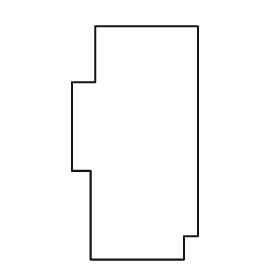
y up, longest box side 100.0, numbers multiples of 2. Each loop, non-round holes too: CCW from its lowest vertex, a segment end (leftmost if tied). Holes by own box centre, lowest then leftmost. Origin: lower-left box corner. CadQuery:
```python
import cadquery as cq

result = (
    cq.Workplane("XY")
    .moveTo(8.0, 0.0)
    .lineTo(48.0, 0.0)
    .lineTo(48.0, 10.0)
    .lineTo(54.0, 10.0)
    .lineTo(54.0, 100.0)
    .lineTo(10.0, 100.0)
    .lineTo(10.0, 76.0)
    .lineTo(0.0, 76.0)
    .lineTo(0.0, 38.0)
    .lineTo(8.0, 38.0)
    .close()
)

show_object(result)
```